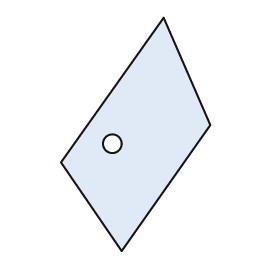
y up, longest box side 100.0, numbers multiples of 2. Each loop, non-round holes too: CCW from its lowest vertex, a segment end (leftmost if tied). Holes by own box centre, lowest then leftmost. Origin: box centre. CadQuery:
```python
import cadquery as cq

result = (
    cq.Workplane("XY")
    .moveTo(-6.0, -50.0)
    .lineTo(32.0, 4.0)
    .lineTo(12.0, 50.0)
    .lineTo(-32.0, -12.0)
    .close()
    .moveTo(-10.0, -4.0)
    .circle(4.0)
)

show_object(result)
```